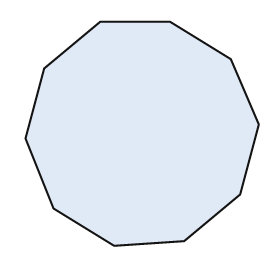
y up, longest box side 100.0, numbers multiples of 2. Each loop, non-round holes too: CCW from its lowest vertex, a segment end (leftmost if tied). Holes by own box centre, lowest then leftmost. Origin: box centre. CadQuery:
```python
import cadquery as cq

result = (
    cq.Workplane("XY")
    .moveTo(-12.0, -48.0)
    .lineTo(18.0, -46.0)
    .lineTo(42.0, -26.0)
    .lineTo(50.0, 4.0)
    .lineTo(38.0, 32.0)
    .lineTo(12.0, 48.0)
    .lineTo(-18.0, 48.0)
    .lineTo(-42.0, 28.0)
    .lineTo(-50.0, -2.0)
    .lineTo(-38.0, -32.0)
    .close()
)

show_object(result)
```